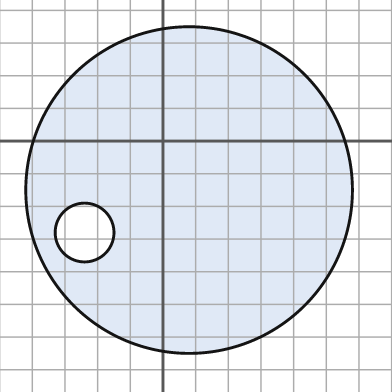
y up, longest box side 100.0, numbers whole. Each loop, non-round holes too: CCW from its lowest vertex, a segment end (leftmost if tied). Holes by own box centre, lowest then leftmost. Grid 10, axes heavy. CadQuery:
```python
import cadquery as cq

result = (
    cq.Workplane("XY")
    .moveTo(8.0, -15.0)
    .circle(50.0)
    .moveTo(-24.0, -28.0)
    .circle(9.0)
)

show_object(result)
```